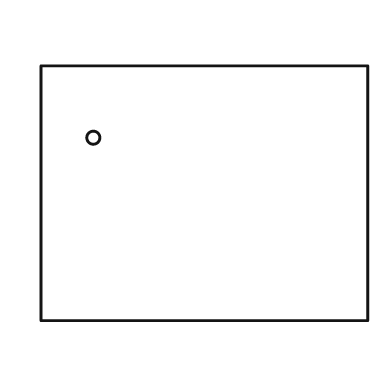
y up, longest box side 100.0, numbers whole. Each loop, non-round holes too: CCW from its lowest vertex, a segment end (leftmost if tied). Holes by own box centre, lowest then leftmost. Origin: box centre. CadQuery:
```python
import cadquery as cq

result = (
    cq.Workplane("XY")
    .moveTo(-50.0, -39.0)
    .lineTo(50.0, -39.0)
    .lineTo(50.0, 39.0)
    .lineTo(-50.0, 39.0)
    .close()
    .moveTo(-34.0, 17.0)
    .circle(2.0)
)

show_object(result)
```